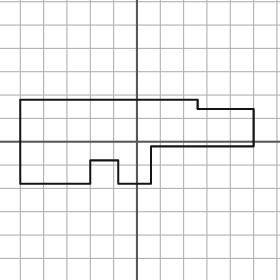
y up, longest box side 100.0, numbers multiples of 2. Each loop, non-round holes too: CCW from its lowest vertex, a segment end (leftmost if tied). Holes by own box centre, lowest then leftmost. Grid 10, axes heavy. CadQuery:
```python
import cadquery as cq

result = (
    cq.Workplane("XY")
    .moveTo(-50.0, -18.0)
    .lineTo(-20.0, -18.0)
    .lineTo(-20.0, -8.0)
    .lineTo(-8.0, -8.0)
    .lineTo(-8.0, -18.0)
    .lineTo(6.0, -18.0)
    .lineTo(6.0, -2.0)
    .lineTo(50.0, -2.0)
    .lineTo(50.0, 14.0)
    .lineTo(26.0, 14.0)
    .lineTo(26.0, 18.0)
    .lineTo(-50.0, 18.0)
    .close()
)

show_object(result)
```